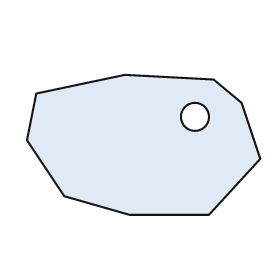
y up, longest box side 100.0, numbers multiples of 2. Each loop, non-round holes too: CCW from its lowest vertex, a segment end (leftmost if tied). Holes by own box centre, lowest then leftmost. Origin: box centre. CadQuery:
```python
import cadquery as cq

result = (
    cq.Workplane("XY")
    .moveTo(-6.0, -30.0)
    .lineTo(28.0, -30.0)
    .lineTo(50.0, -6.0)
    .lineTo(42.0, 18.0)
    .lineTo(30.0, 28.0)
    .lineTo(-8.0, 30.0)
    .lineTo(-46.0, 22.0)
    .lineTo(-50.0, 2.0)
    .lineTo(-34.0, -22.0)
    .close()
    .moveTo(22.0, 12.0)
    .circle(6.0)
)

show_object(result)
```